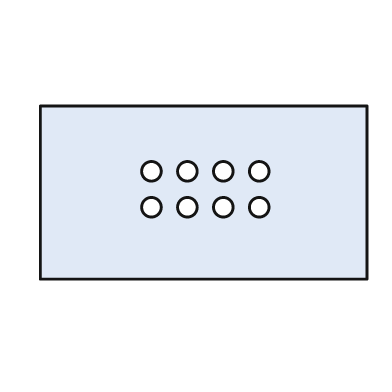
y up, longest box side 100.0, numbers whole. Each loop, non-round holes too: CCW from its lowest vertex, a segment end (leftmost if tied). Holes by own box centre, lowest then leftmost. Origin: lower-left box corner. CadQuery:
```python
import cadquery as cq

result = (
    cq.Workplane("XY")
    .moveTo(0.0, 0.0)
    .lineTo(100.0, 0.0)
    .lineTo(100.0, 53.0)
    .lineTo(0.0, 53.0)
    .close()
    .moveTo(34.0, 22.0)
    .circle(3.0)
    .moveTo(45.0, 22.0)
    .circle(3.0)
    .moveTo(56.0, 22.0)
    .circle(3.0)
    .moveTo(67.0, 22.0)
    .circle(3.0)
    .moveTo(34.0, 33.0)
    .circle(3.0)
    .moveTo(45.0, 33.0)
    .circle(3.0)
    .moveTo(56.0, 33.0)
    .circle(3.0)
    .moveTo(67.0, 33.0)
    .circle(3.0)
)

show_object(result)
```